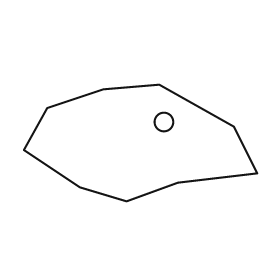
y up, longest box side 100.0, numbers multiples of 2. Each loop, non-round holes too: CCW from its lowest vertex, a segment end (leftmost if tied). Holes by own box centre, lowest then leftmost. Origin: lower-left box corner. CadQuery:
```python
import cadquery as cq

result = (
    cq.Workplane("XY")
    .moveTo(44.0, 0.0)
    .lineTo(66.0, 8.0)
    .lineTo(100.0, 12.0)
    .lineTo(90.0, 32.0)
    .lineTo(58.0, 50.0)
    .lineTo(34.0, 48.0)
    .lineTo(10.0, 40.0)
    .lineTo(0.0, 22.0)
    .lineTo(24.0, 6.0)
    .close()
    .moveTo(60.0, 34.0)
    .circle(4.0)
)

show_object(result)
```